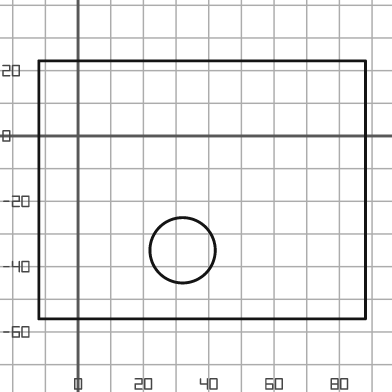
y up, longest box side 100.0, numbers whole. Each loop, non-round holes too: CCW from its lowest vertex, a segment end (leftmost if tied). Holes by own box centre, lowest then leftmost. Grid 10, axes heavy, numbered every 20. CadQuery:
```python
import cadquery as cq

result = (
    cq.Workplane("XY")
    .moveTo(-12.0, -56.0)
    .lineTo(88.0, -56.0)
    .lineTo(88.0, 23.0)
    .lineTo(-12.0, 23.0)
    .close()
    .moveTo(32.0, -35.0)
    .circle(10.0)
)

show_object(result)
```